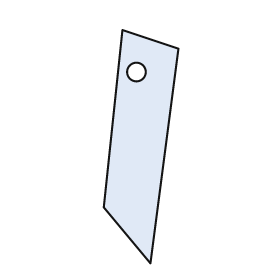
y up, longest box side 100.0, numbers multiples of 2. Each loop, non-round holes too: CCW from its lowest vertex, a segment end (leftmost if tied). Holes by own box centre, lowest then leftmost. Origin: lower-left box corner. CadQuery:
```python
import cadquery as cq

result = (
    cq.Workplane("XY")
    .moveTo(20.0, 0.0)
    .lineTo(32.0, 92.0)
    .lineTo(8.0, 100.0)
    .lineTo(0.0, 24.0)
    .close()
    .moveTo(14.0, 82.0)
    .circle(4.0)
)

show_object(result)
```